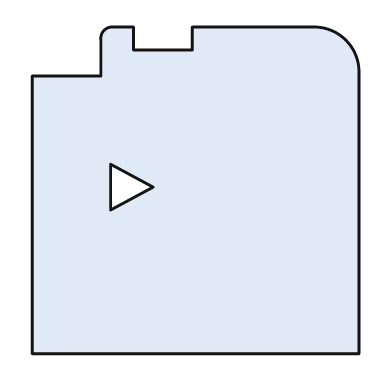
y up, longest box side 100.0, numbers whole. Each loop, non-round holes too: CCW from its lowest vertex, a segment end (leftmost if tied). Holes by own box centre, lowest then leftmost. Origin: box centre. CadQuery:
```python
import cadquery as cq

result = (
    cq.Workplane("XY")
    .moveTo(-50.0, -50.0)
    .lineTo(50.0, -50.0)
    .lineTo(50.0, 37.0)
    .threePointArc((46.0, 46.0), (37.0, 50.0))
    .lineTo(-1.0, 50.0)
    .lineTo(-1.0, 43.0)
    .lineTo(-19.0, 43.0)
    .lineTo(-19.0, 50.0)
    .lineTo(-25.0, 50.0)
    .threePointArc((-28.0, 49.0), (-29.0, 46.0))
    .lineTo(-29.0, 35.0)
    .lineTo(-50.0, 35.0)
    .close()
    .moveTo(-26.0, -6.0)
    .lineTo(-13.0, 1.0)
    .lineTo(-26.0, 8.0)
    .close()
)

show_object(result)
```